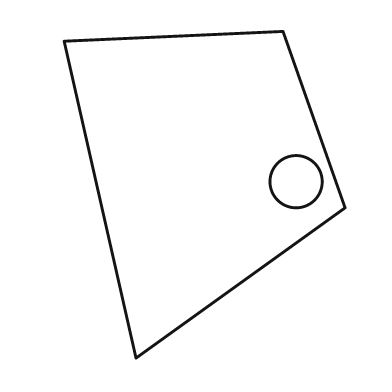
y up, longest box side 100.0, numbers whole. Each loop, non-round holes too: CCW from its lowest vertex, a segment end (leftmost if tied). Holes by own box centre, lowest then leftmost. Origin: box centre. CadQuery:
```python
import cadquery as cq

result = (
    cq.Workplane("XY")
    .moveTo(-21.0, -50.0)
    .lineTo(43.0, -4.0)
    .lineTo(24.0, 50.0)
    .lineTo(-43.0, 47.0)
    .close()
    .moveTo(28.0, 4.0)
    .circle(8.0)
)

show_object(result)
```